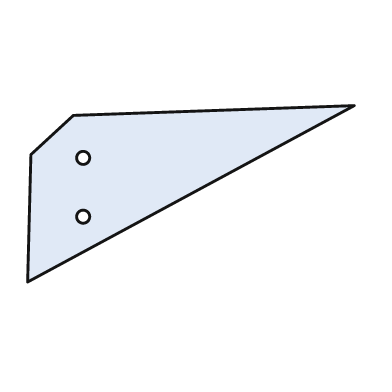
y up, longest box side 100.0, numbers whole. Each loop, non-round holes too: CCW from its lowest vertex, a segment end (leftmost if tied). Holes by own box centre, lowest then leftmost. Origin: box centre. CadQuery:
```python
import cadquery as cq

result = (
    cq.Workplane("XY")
    .moveTo(-50.0, -27.0)
    .lineTo(50.0, 27.0)
    .lineTo(-36.0, 24.0)
    .lineTo(-49.0, 12.0)
    .close()
    .moveTo(-33.0, -7.0)
    .circle(2.0)
    .moveTo(-33.0, 11.0)
    .circle(2.0)
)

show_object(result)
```